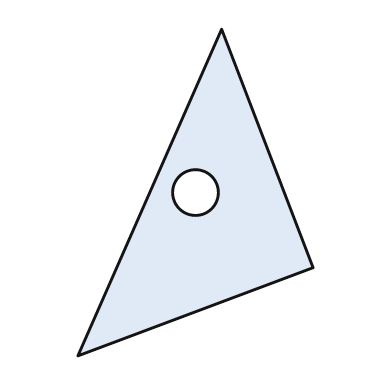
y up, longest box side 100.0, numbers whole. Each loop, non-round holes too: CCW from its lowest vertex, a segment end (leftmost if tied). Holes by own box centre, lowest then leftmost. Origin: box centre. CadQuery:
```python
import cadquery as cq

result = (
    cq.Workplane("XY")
    .moveTo(-36.0, -50.0)
    .lineTo(36.0, -23.0)
    .lineTo(8.0, 50.0)
    .close()
    .moveTo(0.0, 0.0)
    .circle(7.0)
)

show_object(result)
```